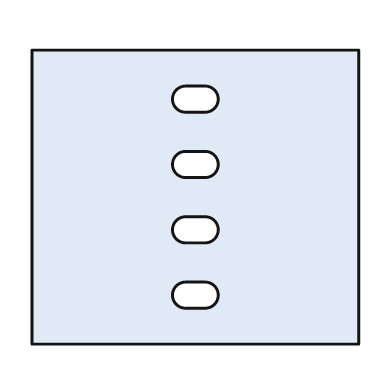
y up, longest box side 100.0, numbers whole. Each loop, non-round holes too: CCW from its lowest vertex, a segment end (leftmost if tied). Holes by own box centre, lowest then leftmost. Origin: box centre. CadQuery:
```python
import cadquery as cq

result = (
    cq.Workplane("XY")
    .moveTo(-50.0, -45.0)
    .lineTo(50.0, -45.0)
    .lineTo(50.0, 45.0)
    .lineTo(-50.0, 45.0)
    .close()
    .moveTo(-3.0, -34.0)
    .lineTo(3.0, -34.0)
    .threePointArc((7.0, -30.0), (3.0, -26.0))
    .lineTo(-3.0, -26.0)
    .threePointArc((-7.0, -30.0), (-3.0, -34.0))
    .close()
    .moveTo(-3.0, -14.0)
    .lineTo(3.0, -14.0)
    .threePointArc((7.0, -10.0), (3.0, -6.0))
    .lineTo(-3.0, -6.0)
    .threePointArc((-7.0, -10.0), (-3.0, -14.0))
    .close()
    .moveTo(-3.0, 6.0)
    .lineTo(3.0, 6.0)
    .threePointArc((7.0, 10.0), (3.0, 14.0))
    .lineTo(-3.0, 14.0)
    .threePointArc((-7.0, 10.0), (-3.0, 6.0))
    .close()
    .moveTo(-3.0, 26.0)
    .lineTo(3.0, 26.0)
    .threePointArc((7.0, 30.0), (3.0, 34.0))
    .lineTo(-3.0, 34.0)
    .threePointArc((-7.0, 30.0), (-3.0, 26.0))
    .close()
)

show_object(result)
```